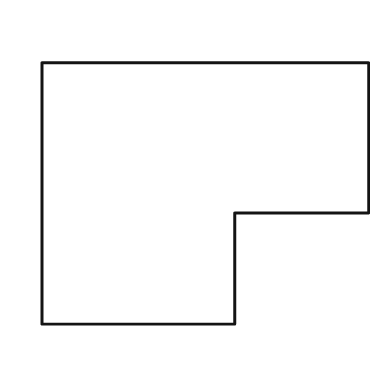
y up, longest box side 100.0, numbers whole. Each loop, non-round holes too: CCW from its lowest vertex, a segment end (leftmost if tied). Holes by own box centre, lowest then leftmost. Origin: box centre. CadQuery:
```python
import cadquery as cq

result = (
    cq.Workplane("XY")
    .moveTo(-50.0, -40.0)
    .lineTo(9.0, -40.0)
    .lineTo(9.0, -6.0)
    .lineTo(50.0, -6.0)
    .lineTo(50.0, 40.0)
    .lineTo(-50.0, 40.0)
    .close()
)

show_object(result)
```